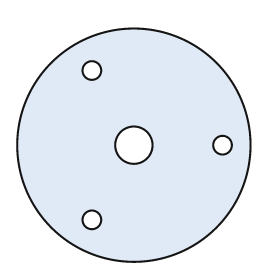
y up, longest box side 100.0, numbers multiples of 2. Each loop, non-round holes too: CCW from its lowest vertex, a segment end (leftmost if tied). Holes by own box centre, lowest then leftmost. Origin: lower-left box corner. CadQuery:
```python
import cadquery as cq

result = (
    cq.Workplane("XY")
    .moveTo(50.0, 50.0)
    .circle(50.0)
    .moveTo(32.0, 18.0)
    .circle(4.0)
    .moveTo(50.0, 50.0)
    .circle(8.0)
    .moveTo(88.0, 50.0)
    .circle(4.0)
    .moveTo(32.0, 82.0)
    .circle(4.0)
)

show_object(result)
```